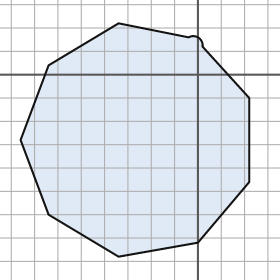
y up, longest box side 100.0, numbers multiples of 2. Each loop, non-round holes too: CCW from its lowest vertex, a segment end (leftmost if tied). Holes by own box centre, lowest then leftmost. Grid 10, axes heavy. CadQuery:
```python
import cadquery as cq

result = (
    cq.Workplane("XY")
    .moveTo(-34.0, -78.0)
    .lineTo(0.0, -72.0)
    .lineTo(22.0, -46.0)
    .lineTo(22.0, -10.0)
    .lineTo(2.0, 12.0)
    .threePointArc((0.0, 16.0), (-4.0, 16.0))
    .lineTo(-34.0, 22.0)
    .lineTo(-64.0, 4.0)
    .lineTo(-76.0, -28.0)
    .lineTo(-64.0, -60.0)
    .close()
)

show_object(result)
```